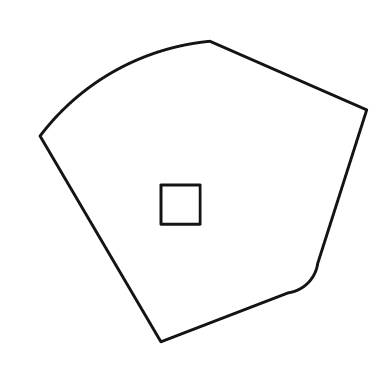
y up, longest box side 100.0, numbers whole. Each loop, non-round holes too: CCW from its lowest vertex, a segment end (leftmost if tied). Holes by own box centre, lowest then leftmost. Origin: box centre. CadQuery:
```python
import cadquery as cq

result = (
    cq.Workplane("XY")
    .moveTo(-13.0, -46.0)
    .lineTo(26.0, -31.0)
    .threePointArc((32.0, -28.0), (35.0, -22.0))
    .lineTo(50.0, 25.0)
    .lineTo(2.0, 46.0)
    .threePointArc((-27.0, 37.0), (-50.0, 17.0))
    .close()
    .moveTo(-13.0, -10.0)
    .lineTo(-1.0, -10.0)
    .lineTo(-1.0, 2.0)
    .lineTo(-13.0, 2.0)
    .close()
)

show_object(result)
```